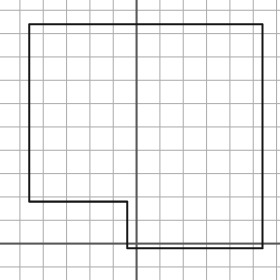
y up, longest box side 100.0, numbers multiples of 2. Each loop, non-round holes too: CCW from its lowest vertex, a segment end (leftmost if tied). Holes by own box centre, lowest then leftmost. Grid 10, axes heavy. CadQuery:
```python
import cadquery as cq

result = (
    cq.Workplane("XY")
    .moveTo(-4.0, -2.0)
    .lineTo(54.0, -2.0)
    .lineTo(54.0, 94.0)
    .lineTo(-46.0, 94.0)
    .lineTo(-46.0, 18.0)
    .lineTo(-4.0, 18.0)
    .close()
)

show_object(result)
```